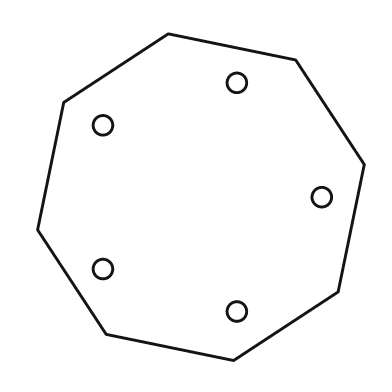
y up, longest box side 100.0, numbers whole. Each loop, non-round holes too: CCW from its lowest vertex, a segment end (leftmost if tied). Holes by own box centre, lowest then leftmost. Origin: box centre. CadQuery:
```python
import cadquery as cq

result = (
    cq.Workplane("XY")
    .moveTo(10.0, -50.0)
    .lineTo(42.0, -29.0)
    .lineTo(50.0, 10.0)
    .lineTo(29.0, 42.0)
    .lineTo(-10.0, 50.0)
    .lineTo(-42.0, 29.0)
    .lineTo(-50.0, -10.0)
    .lineTo(-29.0, -42.0)
    .close()
    .moveTo(11.0, -35.0)
    .circle(3.0)
    .moveTo(-30.0, -22.0)
    .circle(3.0)
    .moveTo(37.0, 0.0)
    .circle(3.0)
    .moveTo(-30.0, 22.0)
    .circle(3.0)
    .moveTo(11.0, 35.0)
    .circle(3.0)
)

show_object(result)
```